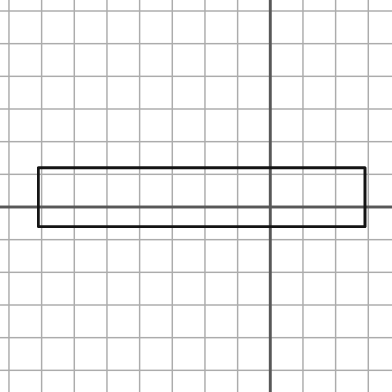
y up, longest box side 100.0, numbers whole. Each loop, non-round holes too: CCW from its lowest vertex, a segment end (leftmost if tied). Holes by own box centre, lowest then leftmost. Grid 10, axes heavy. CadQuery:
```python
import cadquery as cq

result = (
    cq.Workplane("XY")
    .moveTo(-71.0, -6.0)
    .lineTo(29.0, -6.0)
    .lineTo(29.0, 12.0)
    .lineTo(-71.0, 12.0)
    .close()
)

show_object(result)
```